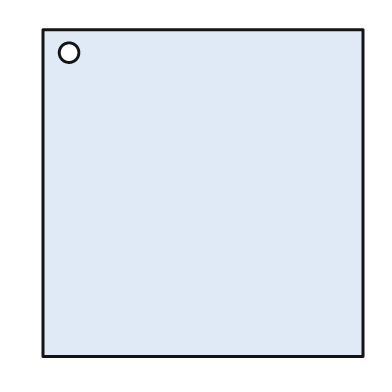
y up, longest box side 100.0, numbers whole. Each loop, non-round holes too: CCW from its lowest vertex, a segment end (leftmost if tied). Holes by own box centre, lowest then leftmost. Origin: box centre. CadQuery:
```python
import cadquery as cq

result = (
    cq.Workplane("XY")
    .moveTo(-49.0, -50.0)
    .lineTo(49.0, -50.0)
    .lineTo(49.0, 50.0)
    .lineTo(-49.0, 50.0)
    .close()
    .moveTo(-41.0, 43.0)
    .circle(3.0)
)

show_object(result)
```